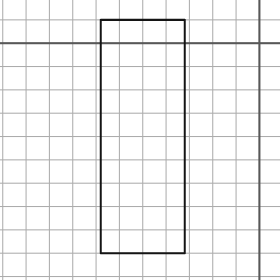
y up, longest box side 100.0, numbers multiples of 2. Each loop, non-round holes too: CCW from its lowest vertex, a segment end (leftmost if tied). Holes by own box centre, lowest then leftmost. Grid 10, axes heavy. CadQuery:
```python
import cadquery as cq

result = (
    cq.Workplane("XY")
    .moveTo(-68.0, -90.0)
    .lineTo(-32.0, -90.0)
    .lineTo(-32.0, 10.0)
    .lineTo(-68.0, 10.0)
    .close()
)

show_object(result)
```